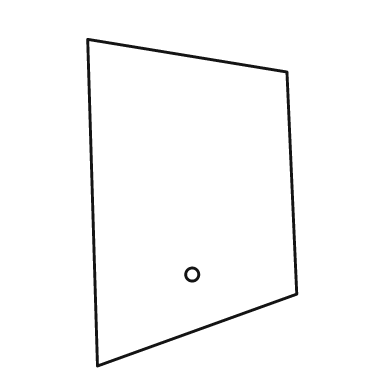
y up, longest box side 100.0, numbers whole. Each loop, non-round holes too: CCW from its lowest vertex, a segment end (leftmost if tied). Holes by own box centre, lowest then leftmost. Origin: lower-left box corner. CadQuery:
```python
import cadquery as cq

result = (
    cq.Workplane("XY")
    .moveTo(3.0, 0.0)
    .lineTo(64.0, 22.0)
    .lineTo(61.0, 90.0)
    .lineTo(0.0, 100.0)
    .close()
    .moveTo(32.0, 28.0)
    .circle(2.0)
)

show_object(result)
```